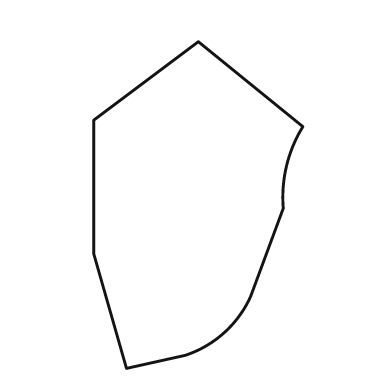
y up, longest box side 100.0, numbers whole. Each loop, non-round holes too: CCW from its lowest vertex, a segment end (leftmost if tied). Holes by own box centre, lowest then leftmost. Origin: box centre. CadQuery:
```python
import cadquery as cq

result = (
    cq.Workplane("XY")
    .moveTo(-22.0, -50.0)
    .lineTo(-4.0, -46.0)
    .threePointArc((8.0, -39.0), (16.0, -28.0))
    .lineTo(26.0, -1.0)
    .threePointArc((27.0, 12.0), (32.0, 24.0))
    .lineTo(0.0, 50.0)
    .lineTo(-32.0, 26.0)
    .lineTo(-32.0, -15.0)
    .close()
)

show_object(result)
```